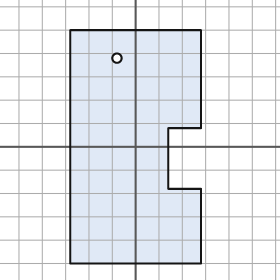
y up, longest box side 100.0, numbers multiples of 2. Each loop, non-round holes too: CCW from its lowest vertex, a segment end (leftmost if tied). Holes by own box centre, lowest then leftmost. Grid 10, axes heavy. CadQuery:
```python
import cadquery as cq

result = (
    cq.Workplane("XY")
    .moveTo(-28.0, -50.0)
    .lineTo(28.0, -50.0)
    .lineTo(28.0, -18.0)
    .lineTo(14.0, -18.0)
    .lineTo(14.0, 8.0)
    .lineTo(28.0, 8.0)
    .lineTo(28.0, 50.0)
    .lineTo(-28.0, 50.0)
    .close()
    .moveTo(-8.0, 38.0)
    .circle(2.0)
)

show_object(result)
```